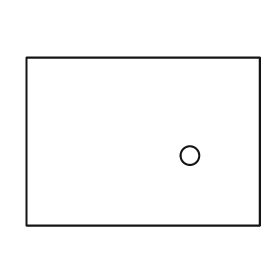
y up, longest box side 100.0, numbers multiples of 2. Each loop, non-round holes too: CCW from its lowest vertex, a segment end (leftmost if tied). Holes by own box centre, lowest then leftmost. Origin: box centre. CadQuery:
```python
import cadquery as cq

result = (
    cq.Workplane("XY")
    .moveTo(-50.0, -36.0)
    .lineTo(50.0, -36.0)
    .lineTo(50.0, 36.0)
    .lineTo(-50.0, 36.0)
    .close()
    .moveTo(20.0, -6.0)
    .circle(4.0)
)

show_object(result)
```